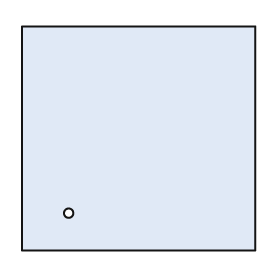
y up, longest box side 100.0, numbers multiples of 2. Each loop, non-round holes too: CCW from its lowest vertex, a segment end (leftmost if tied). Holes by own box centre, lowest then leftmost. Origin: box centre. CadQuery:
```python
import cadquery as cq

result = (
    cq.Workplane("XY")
    .moveTo(-50.0, -48.0)
    .lineTo(50.0, -48.0)
    .lineTo(50.0, 48.0)
    .lineTo(-50.0, 48.0)
    .close()
    .moveTo(-30.0, -32.0)
    .circle(2.0)
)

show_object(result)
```